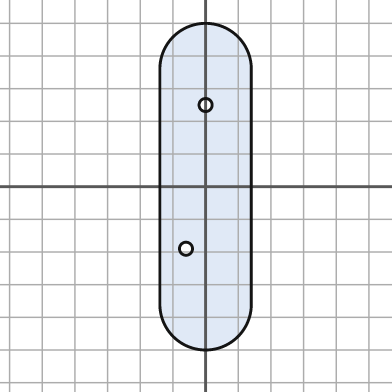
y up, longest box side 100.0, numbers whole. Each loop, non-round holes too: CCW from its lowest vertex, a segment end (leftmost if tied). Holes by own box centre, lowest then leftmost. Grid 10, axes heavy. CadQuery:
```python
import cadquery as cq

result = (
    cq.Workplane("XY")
    .moveTo(-14.0, -36.0)
    .threePointArc((0.0, -50.0), (14.0, -36.0))
    .lineTo(14.0, 36.0)
    .threePointArc((0.0, 50.0), (-14.0, 36.0))
    .close()
    .moveTo(-6.0, -19.0)
    .circle(2.0)
    .moveTo(0.0, 25.0)
    .circle(2.0)
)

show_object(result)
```